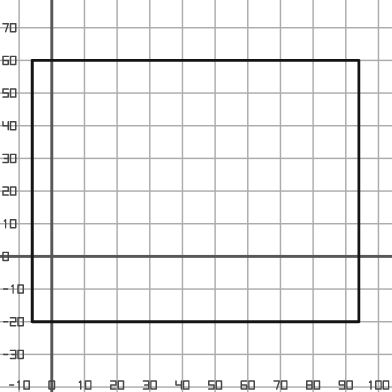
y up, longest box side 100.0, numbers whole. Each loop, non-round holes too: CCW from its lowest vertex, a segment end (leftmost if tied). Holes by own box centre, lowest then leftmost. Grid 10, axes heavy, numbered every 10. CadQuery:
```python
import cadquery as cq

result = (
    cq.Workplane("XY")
    .moveTo(-6.0, -20.0)
    .lineTo(94.0, -20.0)
    .lineTo(94.0, 60.0)
    .lineTo(-6.0, 60.0)
    .close()
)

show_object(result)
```